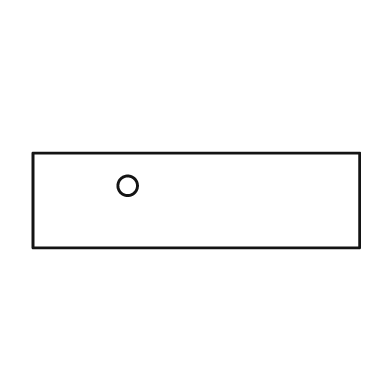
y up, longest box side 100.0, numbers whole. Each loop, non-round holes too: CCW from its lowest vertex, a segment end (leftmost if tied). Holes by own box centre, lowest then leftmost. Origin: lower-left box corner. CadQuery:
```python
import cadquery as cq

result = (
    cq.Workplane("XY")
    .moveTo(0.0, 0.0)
    .lineTo(100.0, 0.0)
    .lineTo(100.0, 29.0)
    .lineTo(0.0, 29.0)
    .close()
    .moveTo(29.0, 19.0)
    .circle(3.0)
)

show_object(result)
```